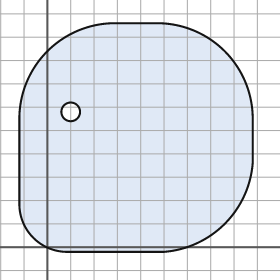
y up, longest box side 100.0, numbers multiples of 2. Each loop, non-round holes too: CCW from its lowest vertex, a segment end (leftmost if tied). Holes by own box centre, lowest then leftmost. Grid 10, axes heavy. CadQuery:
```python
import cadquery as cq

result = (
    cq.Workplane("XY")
    .moveTo(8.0, -2.0)
    .lineTo(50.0, -2.0)
    .threePointArc((76.0, 10.0), (88.0, 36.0))
    .lineTo(88.0, 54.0)
    .threePointArc((76.0, 84.0), (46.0, 96.0))
    .lineTo(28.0, 96.0)
    .threePointArc((0.0, 84.0), (-12.0, 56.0))
    .lineTo(-12.0, 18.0)
    .threePointArc((-6.0, 4.0), (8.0, -2.0))
    .close()
    .moveTo(10.0, 58.0)
    .circle(4.0)
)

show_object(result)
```